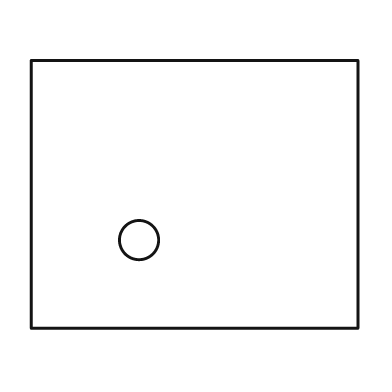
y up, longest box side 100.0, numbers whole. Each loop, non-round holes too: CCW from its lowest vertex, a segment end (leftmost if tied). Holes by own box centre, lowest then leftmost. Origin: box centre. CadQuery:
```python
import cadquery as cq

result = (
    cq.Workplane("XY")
    .moveTo(-50.0, -41.0)
    .lineTo(50.0, -41.0)
    .lineTo(50.0, 41.0)
    .lineTo(-50.0, 41.0)
    .close()
    .moveTo(-17.0, -14.0)
    .circle(6.0)
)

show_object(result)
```